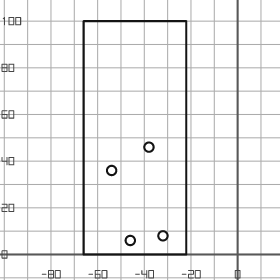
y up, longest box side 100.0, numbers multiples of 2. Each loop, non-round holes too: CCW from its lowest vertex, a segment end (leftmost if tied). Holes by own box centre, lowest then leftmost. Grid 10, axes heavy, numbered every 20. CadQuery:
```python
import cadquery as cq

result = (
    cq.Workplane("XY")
    .moveTo(-66.0, 0.0)
    .lineTo(-22.0, 0.0)
    .lineTo(-22.0, 100.0)
    .lineTo(-66.0, 100.0)
    .close()
    .moveTo(-46.0, 6.0)
    .circle(2.0)
    .moveTo(-32.0, 8.0)
    .circle(2.0)
    .moveTo(-54.0, 36.0)
    .circle(2.0)
    .moveTo(-38.0, 46.0)
    .circle(2.0)
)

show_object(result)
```